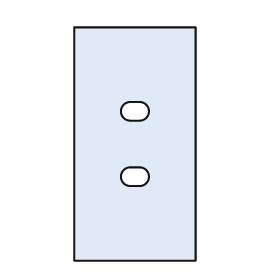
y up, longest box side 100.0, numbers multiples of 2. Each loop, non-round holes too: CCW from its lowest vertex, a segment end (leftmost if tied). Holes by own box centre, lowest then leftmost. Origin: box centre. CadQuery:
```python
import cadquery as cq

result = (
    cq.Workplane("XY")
    .moveTo(-26.0, -50.0)
    .lineTo(26.0, -50.0)
    .lineTo(26.0, 50.0)
    .lineTo(-26.0, 50.0)
    .close()
    .moveTo(-2.0, -18.0)
    .lineTo(2.0, -18.0)
    .threePointArc((6.0, -14.0), (2.0, -10.0))
    .lineTo(-2.0, -10.0)
    .threePointArc((-6.0, -14.0), (-2.0, -18.0))
    .close()
    .moveTo(-2.0, 10.0)
    .lineTo(2.0, 10.0)
    .threePointArc((6.0, 14.0), (2.0, 18.0))
    .lineTo(-2.0, 18.0)
    .threePointArc((-6.0, 14.0), (-2.0, 10.0))
    .close()
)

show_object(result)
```